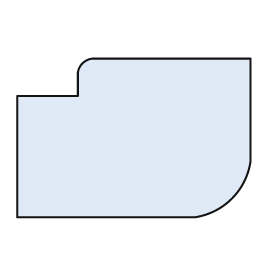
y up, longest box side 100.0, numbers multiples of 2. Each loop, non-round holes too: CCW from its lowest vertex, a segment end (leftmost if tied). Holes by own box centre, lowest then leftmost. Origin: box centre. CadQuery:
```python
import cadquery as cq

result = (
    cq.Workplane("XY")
    .moveTo(-50.0, -34.0)
    .lineTo(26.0, -34.0)
    .threePointArc((42.0, -26.0), (50.0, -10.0))
    .lineTo(50.0, 34.0)
    .lineTo(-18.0, 34.0)
    .threePointArc((-22.0, 32.0), (-24.0, 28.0))
    .lineTo(-24.0, 18.0)
    .lineTo(-50.0, 18.0)
    .close()
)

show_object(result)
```